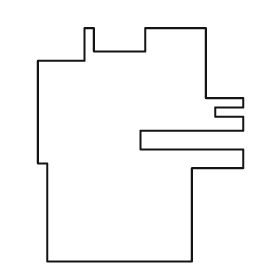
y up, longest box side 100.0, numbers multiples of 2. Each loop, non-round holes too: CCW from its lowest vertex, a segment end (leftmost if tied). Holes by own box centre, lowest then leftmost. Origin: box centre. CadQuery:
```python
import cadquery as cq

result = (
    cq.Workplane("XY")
    .moveTo(-40.0, -50.0)
    .lineTo(22.0, -50.0)
    .lineTo(22.0, -10.0)
    .lineTo(44.0, -10.0)
    .lineTo(44.0, -2.0)
    .lineTo(0.0, -2.0)
    .lineTo(0.0, 6.0)
    .lineTo(44.0, 6.0)
    .lineTo(44.0, 12.0)
    .lineTo(32.0, 12.0)
    .lineTo(32.0, 16.0)
    .lineTo(44.0, 16.0)
    .lineTo(44.0, 20.0)
    .lineTo(28.0, 20.0)
    .lineTo(28.0, 50.0)
    .lineTo(2.0, 50.0)
    .lineTo(2.0, 40.0)
    .lineTo(-20.0, 40.0)
    .lineTo(-20.0, 50.0)
    .lineTo(-24.0, 50.0)
    .lineTo(-24.0, 36.0)
    .lineTo(-44.0, 36.0)
    .lineTo(-44.0, -8.0)
    .lineTo(-40.0, -8.0)
    .close()
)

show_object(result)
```